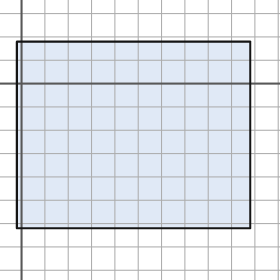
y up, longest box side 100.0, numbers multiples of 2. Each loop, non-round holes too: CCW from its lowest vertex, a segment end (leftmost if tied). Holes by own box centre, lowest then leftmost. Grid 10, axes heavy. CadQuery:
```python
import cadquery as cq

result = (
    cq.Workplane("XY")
    .moveTo(-2.0, -62.0)
    .lineTo(98.0, -62.0)
    .lineTo(98.0, 18.0)
    .lineTo(-2.0, 18.0)
    .close()
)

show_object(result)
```